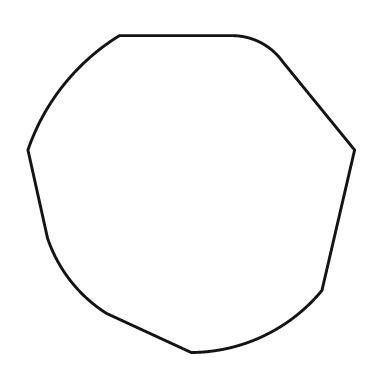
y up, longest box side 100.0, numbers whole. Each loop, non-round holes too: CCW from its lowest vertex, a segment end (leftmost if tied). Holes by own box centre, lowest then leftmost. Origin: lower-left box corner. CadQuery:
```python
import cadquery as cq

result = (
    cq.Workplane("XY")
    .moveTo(50.0, 0.0)
    .threePointArc((72.0, 5.0), (90.0, 19.0))
    .lineTo(100.0, 62.0)
    .lineTo(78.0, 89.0)
    .threePointArc((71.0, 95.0), (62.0, 97.0))
    .lineTo(28.0, 97.0)
    .threePointArc((11.0, 82.0), (0.0, 62.0))
    .lineTo(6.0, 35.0)
    .threePointArc((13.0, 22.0), (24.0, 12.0))
    .close()
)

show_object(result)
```